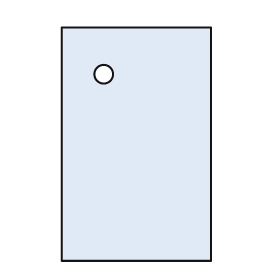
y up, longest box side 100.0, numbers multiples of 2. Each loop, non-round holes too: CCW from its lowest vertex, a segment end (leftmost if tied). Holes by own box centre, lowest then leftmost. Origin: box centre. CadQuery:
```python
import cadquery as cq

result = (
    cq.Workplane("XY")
    .moveTo(-32.0, -50.0)
    .lineTo(32.0, -50.0)
    .lineTo(32.0, 50.0)
    .lineTo(-32.0, 50.0)
    .close()
    .moveTo(-14.0, 30.0)
    .circle(4.0)
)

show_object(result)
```